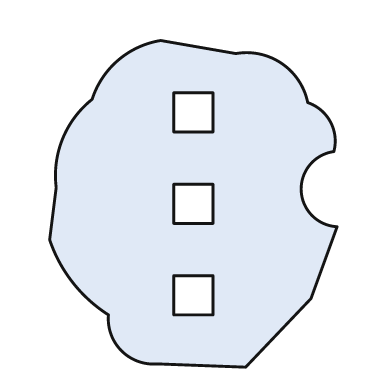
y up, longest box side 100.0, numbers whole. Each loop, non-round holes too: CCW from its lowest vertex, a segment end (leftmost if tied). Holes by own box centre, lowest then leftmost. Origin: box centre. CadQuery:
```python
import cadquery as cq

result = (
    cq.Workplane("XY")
    .moveTo(16.0, -50.0)
    .lineTo(36.0, -29.0)
    .lineTo(44.0, -7.0)
    .threePointArc((33.0, 4.0), (43.0, 16.0))
    .threePointArc((42.0, 25.0), (35.0, 31.0))
    .threePointArc((27.0, 43.0), (13.0, 46.0))
    .lineTo(-10.0, 50.0)
    .threePointArc((-23.0, 44.0), (-31.0, 32.0))
    .threePointArc((-40.0, 20.0), (-42.0, 5.0))
    .lineTo(-44.0, -11.0)
    .threePointArc((-37.0, -24.0), (-26.0, -34.0))
    .threePointArc((-22.0, -45.0), (-11.0, -49.0))
    .close()
    .moveTo(-6.0, -34.0)
    .lineTo(6.0, -34.0)
    .lineTo(6.0, -22.0)
    .lineTo(-6.0, -22.0)
    .close()
    .moveTo(-6.0, -6.0)
    .lineTo(6.0, -6.0)
    .lineTo(6.0, 6.0)
    .lineTo(-6.0, 6.0)
    .close()
    .moveTo(-6.0, 22.0)
    .lineTo(6.0, 22.0)
    .lineTo(6.0, 34.0)
    .lineTo(-6.0, 34.0)
    .close()
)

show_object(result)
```